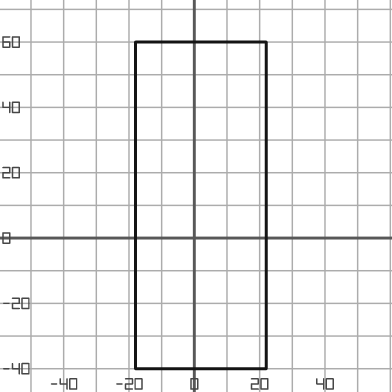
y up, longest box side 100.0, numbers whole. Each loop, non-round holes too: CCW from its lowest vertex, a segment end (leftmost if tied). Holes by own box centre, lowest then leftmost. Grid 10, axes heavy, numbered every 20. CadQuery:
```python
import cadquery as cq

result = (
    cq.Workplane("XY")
    .moveTo(-18.0, -40.0)
    .lineTo(22.0, -40.0)
    .lineTo(22.0, 60.0)
    .lineTo(-18.0, 60.0)
    .close()
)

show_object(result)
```